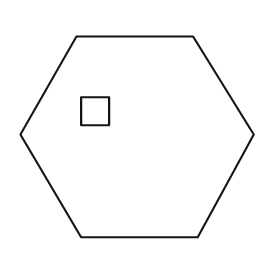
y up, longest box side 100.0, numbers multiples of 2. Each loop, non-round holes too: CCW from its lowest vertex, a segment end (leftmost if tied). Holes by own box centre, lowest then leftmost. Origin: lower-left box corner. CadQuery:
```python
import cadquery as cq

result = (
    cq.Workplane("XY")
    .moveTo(26.0, 0.0)
    .lineTo(76.0, 0.0)
    .lineTo(100.0, 44.0)
    .lineTo(74.0, 86.0)
    .lineTo(24.0, 86.0)
    .lineTo(0.0, 44.0)
    .close()
    .moveTo(26.0, 48.0)
    .lineTo(38.0, 48.0)
    .lineTo(38.0, 60.0)
    .lineTo(26.0, 60.0)
    .close()
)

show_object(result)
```